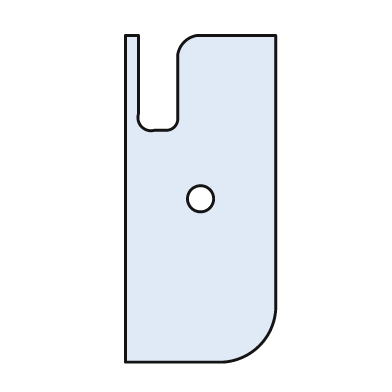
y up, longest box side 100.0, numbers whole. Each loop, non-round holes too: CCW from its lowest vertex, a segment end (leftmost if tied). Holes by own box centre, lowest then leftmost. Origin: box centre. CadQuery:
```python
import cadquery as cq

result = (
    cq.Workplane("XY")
    .moveTo(-23.0, -50.0)
    .lineTo(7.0, -50.0)
    .threePointArc((18.0, -45.0), (23.0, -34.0))
    .lineTo(23.0, 50.0)
    .lineTo(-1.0, 50.0)
    .threePointArc((-5.0, 48.0), (-7.0, 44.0))
    .lineTo(-7.0, 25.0)
    .threePointArc((-8.0, 22.0), (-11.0, 21.0))
    .lineTo(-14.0, 21.0)
    .threePointArc((-18.0, 22.0), (-19.0, 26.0))
    .lineTo(-19.0, 50.0)
    .lineTo(-23.0, 50.0)
    .close()
    .moveTo(0.0, 0.0)
    .circle(4.0)
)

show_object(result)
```